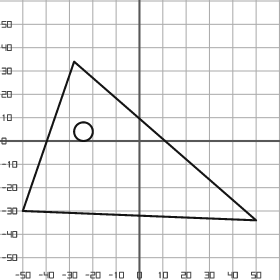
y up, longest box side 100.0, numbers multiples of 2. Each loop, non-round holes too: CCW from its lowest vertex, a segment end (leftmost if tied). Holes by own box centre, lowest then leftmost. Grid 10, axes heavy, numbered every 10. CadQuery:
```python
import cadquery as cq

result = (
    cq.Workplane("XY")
    .moveTo(50.0, -34.0)
    .lineTo(-28.0, 34.0)
    .lineTo(-50.0, -30.0)
    .close()
    .moveTo(-24.0, 4.0)
    .circle(4.0)
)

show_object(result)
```